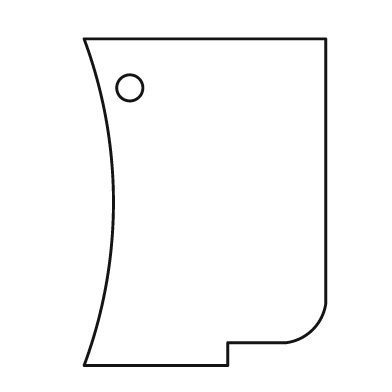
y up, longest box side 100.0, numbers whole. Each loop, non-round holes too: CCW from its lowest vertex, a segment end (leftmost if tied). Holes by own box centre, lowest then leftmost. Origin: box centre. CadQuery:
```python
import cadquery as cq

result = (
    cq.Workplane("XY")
    .moveTo(-37.0, -50.0)
    .lineTo(7.0, -50.0)
    .lineTo(7.0, -43.0)
    .lineTo(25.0, -43.0)
    .threePointArc((33.0, -39.0), (37.0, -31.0))
    .lineTo(37.0, 50.0)
    .lineTo(-37.0, 50.0)
    .threePointArc((-28.0, 0.0), (-37.0, -50.0))
    .close()
    .moveTo(-23.0, 35.0)
    .circle(4.0)
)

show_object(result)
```